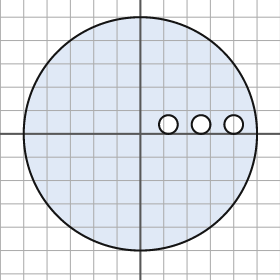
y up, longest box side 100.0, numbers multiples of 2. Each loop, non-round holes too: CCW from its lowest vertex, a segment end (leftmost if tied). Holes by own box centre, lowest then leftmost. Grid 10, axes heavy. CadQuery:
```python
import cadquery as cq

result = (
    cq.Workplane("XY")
    .moveTo(0.0, 0.0)
    .circle(50.0)
    .moveTo(12.0, 4.0)
    .circle(4.0)
    .moveTo(26.0, 4.0)
    .circle(4.0)
    .moveTo(40.0, 4.0)
    .circle(4.0)
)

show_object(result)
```